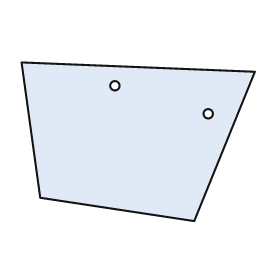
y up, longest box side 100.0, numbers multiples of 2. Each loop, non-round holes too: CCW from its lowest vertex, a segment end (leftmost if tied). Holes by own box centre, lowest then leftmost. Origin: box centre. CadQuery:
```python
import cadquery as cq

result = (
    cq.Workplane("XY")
    .moveTo(24.0, -34.0)
    .lineTo(50.0, 30.0)
    .lineTo(-50.0, 34.0)
    .lineTo(-42.0, -24.0)
    .close()
    .moveTo(30.0, 12.0)
    .circle(2.0)
    .moveTo(-10.0, 24.0)
    .circle(2.0)
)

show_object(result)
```